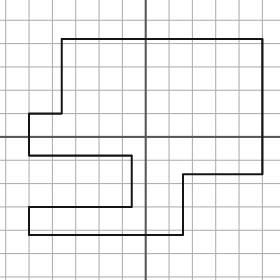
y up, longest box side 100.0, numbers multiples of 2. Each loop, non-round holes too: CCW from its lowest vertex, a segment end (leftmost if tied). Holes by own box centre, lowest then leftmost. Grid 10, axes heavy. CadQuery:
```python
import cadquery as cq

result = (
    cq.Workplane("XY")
    .moveTo(-50.0, -42.0)
    .lineTo(16.0, -42.0)
    .lineTo(16.0, -16.0)
    .lineTo(50.0, -16.0)
    .lineTo(50.0, 42.0)
    .lineTo(-36.0, 42.0)
    .lineTo(-36.0, 10.0)
    .lineTo(-50.0, 10.0)
    .lineTo(-50.0, -8.0)
    .lineTo(-6.0, -8.0)
    .lineTo(-6.0, -30.0)
    .lineTo(-50.0, -30.0)
    .close()
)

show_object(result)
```